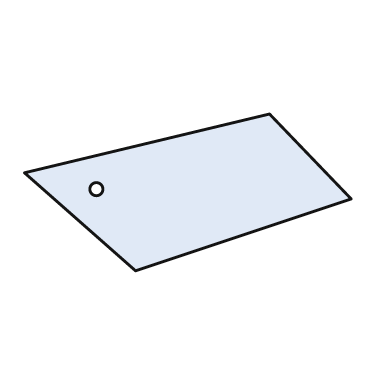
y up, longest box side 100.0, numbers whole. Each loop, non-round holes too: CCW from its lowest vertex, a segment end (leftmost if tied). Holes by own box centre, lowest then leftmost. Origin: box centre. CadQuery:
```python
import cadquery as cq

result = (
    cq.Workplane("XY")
    .moveTo(-16.0, -24.0)
    .lineTo(50.0, -2.0)
    .lineTo(25.0, 24.0)
    .lineTo(-50.0, 6.0)
    .close()
    .moveTo(-28.0, 1.0)
    .circle(2.0)
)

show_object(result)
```